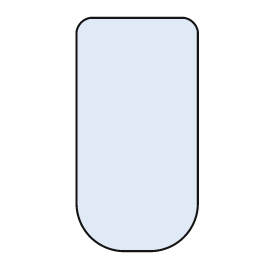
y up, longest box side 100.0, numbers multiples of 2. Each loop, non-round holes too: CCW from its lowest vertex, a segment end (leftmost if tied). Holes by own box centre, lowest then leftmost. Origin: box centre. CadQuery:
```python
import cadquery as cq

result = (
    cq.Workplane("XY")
    .moveTo(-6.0, -50.0)
    .lineTo(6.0, -50.0)
    .threePointArc((20.0, -44.0), (26.0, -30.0))
    .lineTo(26.0, 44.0)
    .threePointArc((24.0, 48.0), (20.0, 50.0))
    .lineTo(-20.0, 50.0)
    .threePointArc((-24.0, 48.0), (-26.0, 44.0))
    .lineTo(-26.0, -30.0)
    .threePointArc((-20.0, -44.0), (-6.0, -50.0))
    .close()
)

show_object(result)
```